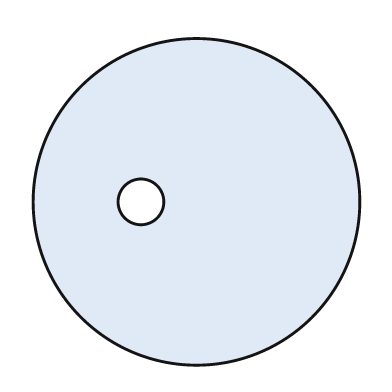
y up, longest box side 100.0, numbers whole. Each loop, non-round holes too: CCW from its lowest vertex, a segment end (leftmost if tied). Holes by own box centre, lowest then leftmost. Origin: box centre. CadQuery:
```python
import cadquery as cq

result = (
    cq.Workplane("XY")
    .moveTo(0.0, 0.0)
    .circle(50.0)
    .moveTo(-17.0, 0.0)
    .circle(7.0)
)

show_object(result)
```